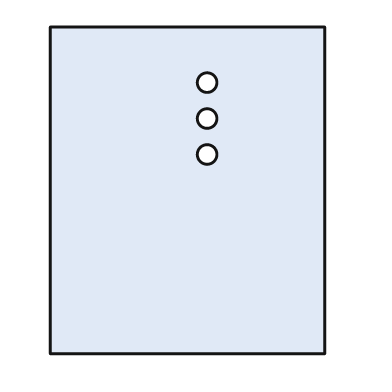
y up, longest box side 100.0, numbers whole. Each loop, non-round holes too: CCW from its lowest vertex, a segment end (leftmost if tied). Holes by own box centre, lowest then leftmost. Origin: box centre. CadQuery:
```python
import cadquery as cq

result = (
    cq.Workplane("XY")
    .moveTo(-42.0, -50.0)
    .lineTo(42.0, -50.0)
    .lineTo(42.0, 50.0)
    .lineTo(-42.0, 50.0)
    .close()
    .moveTo(6.0, 11.0)
    .circle(3.0)
    .moveTo(6.0, 22.0)
    .circle(3.0)
    .moveTo(6.0, 33.0)
    .circle(3.0)
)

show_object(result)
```